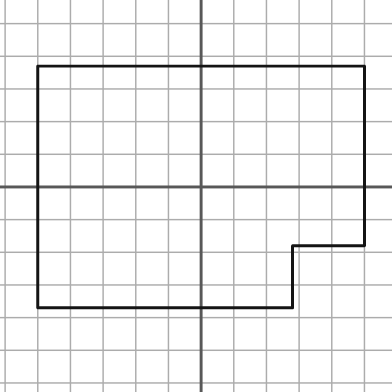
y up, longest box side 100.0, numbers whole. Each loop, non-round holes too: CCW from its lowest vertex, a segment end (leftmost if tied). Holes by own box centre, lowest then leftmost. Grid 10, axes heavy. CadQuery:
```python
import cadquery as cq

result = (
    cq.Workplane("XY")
    .moveTo(-50.0, -37.0)
    .lineTo(28.0, -37.0)
    .lineTo(28.0, -18.0)
    .lineTo(50.0, -18.0)
    .lineTo(50.0, 37.0)
    .lineTo(-50.0, 37.0)
    .close()
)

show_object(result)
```